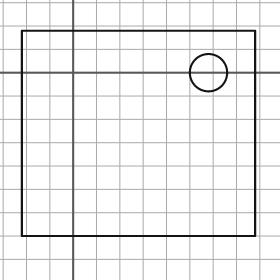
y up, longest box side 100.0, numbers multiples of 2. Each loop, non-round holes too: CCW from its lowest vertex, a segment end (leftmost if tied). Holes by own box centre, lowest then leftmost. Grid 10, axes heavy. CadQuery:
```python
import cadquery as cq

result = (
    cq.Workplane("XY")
    .moveTo(-22.0, -70.0)
    .lineTo(78.0, -70.0)
    .lineTo(78.0, 18.0)
    .lineTo(-22.0, 18.0)
    .close()
    .moveTo(58.0, 0.0)
    .circle(8.0)
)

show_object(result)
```